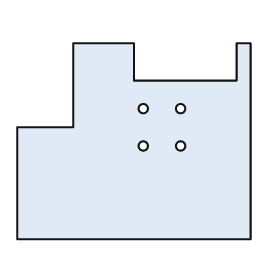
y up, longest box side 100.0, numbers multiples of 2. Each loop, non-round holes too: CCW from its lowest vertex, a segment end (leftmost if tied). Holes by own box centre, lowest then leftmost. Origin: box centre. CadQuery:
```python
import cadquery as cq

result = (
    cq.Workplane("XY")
    .moveTo(-50.0, -42.0)
    .lineTo(50.0, -42.0)
    .lineTo(50.0, 42.0)
    .lineTo(44.0, 42.0)
    .lineTo(44.0, 26.0)
    .lineTo(0.0, 26.0)
    .lineTo(0.0, 42.0)
    .lineTo(-26.0, 42.0)
    .lineTo(-26.0, 6.0)
    .lineTo(-50.0, 6.0)
    .close()
    .moveTo(4.0, -2.0)
    .circle(2.0)
    .moveTo(20.0, -2.0)
    .circle(2.0)
    .moveTo(4.0, 14.0)
    .circle(2.0)
    .moveTo(20.0, 14.0)
    .circle(2.0)
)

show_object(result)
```